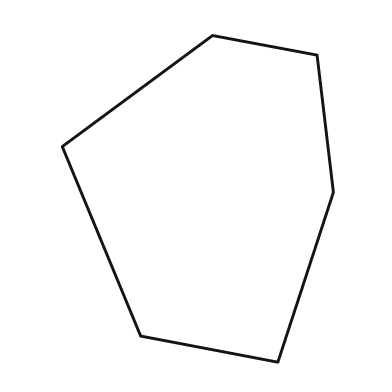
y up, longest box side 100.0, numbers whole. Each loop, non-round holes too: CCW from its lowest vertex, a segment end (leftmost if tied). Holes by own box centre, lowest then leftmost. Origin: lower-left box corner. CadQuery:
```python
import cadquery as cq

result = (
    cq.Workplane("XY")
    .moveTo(66.0, 0.0)
    .lineTo(83.0, 52.0)
    .lineTo(78.0, 94.0)
    .lineTo(46.0, 100.0)
    .lineTo(0.0, 66.0)
    .lineTo(24.0, 8.0)
    .close()
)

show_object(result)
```